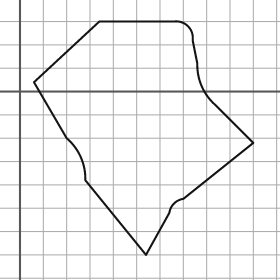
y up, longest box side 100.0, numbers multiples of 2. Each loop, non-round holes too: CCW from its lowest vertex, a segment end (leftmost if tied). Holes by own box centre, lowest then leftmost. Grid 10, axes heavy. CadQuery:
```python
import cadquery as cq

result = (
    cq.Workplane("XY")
    .moveTo(54.0, -70.0)
    .lineTo(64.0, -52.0)
    .threePointArc((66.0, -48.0), (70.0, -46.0))
    .lineTo(100.0, -22.0)
    .lineTo(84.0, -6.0)
    .threePointArc((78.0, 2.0), (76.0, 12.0))
    .lineTo(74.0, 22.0)
    .threePointArc((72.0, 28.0), (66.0, 30.0))
    .lineTo(34.0, 30.0)
    .lineTo(6.0, 4.0)
    .lineTo(20.0, -20.0)
    .threePointArc((26.0, -28.0), (28.0, -38.0))
    .close()
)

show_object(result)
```